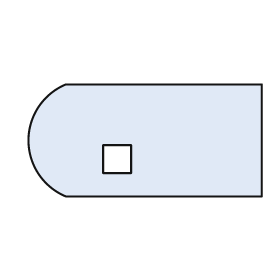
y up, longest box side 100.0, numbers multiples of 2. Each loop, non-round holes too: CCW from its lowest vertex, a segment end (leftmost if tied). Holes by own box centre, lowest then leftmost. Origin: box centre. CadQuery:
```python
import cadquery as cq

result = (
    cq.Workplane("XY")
    .moveTo(-34.0, -24.0)
    .lineTo(50.0, -24.0)
    .lineTo(50.0, 24.0)
    .lineTo(-34.0, 24.0)
    .threePointArc((-50.0, 0.0), (-34.0, -24.0))
    .close()
    .moveTo(-18.0, -14.0)
    .lineTo(-6.0, -14.0)
    .lineTo(-6.0, -2.0)
    .lineTo(-18.0, -2.0)
    .close()
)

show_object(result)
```